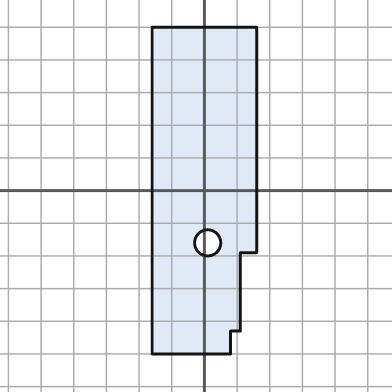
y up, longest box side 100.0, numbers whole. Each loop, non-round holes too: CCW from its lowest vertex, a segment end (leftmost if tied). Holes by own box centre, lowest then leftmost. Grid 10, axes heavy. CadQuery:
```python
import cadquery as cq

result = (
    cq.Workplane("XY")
    .moveTo(-16.0, -50.0)
    .lineTo(8.0, -50.0)
    .lineTo(8.0, -43.0)
    .lineTo(11.0, -43.0)
    .lineTo(11.0, -19.0)
    .lineTo(16.0, -19.0)
    .lineTo(16.0, 50.0)
    .lineTo(-16.0, 50.0)
    .close()
    .moveTo(1.0, -16.0)
    .circle(4.0)
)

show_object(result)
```